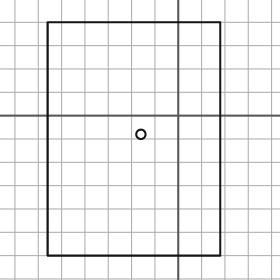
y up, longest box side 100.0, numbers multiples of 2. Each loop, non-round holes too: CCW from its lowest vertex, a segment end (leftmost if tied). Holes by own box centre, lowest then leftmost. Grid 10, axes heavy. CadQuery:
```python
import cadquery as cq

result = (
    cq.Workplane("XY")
    .moveTo(-56.0, -60.0)
    .lineTo(18.0, -60.0)
    .lineTo(18.0, 40.0)
    .lineTo(-56.0, 40.0)
    .close()
    .moveTo(-16.0, -8.0)
    .circle(2.0)
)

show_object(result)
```